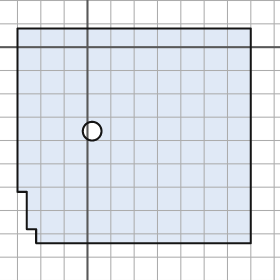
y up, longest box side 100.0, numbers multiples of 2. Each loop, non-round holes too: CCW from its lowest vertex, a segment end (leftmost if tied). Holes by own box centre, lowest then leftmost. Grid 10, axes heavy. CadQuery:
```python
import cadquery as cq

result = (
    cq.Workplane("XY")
    .moveTo(-22.0, -84.0)
    .lineTo(70.0, -84.0)
    .lineTo(70.0, 8.0)
    .lineTo(-30.0, 8.0)
    .lineTo(-30.0, -62.0)
    .lineTo(-26.0, -62.0)
    .lineTo(-26.0, -78.0)
    .lineTo(-22.0, -78.0)
    .close()
    .moveTo(2.0, -36.0)
    .circle(4.0)
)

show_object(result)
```